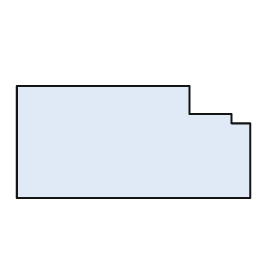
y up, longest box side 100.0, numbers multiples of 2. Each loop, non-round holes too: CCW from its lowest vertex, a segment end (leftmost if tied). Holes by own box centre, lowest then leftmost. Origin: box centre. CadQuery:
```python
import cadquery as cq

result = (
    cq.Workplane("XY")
    .moveTo(-50.0, -24.0)
    .lineTo(50.0, -24.0)
    .lineTo(50.0, 8.0)
    .lineTo(42.0, 8.0)
    .lineTo(42.0, 12.0)
    .lineTo(24.0, 12.0)
    .lineTo(24.0, 24.0)
    .lineTo(-50.0, 24.0)
    .close()
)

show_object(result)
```